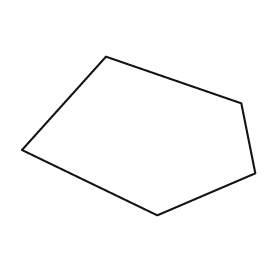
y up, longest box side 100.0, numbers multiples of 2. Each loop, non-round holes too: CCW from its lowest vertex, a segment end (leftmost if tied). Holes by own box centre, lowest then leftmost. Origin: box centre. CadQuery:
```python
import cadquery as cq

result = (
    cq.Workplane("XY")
    .moveTo(8.0, -34.0)
    .lineTo(50.0, -16.0)
    .lineTo(44.0, 14.0)
    .lineTo(-14.0, 34.0)
    .lineTo(-50.0, -6.0)
    .close()
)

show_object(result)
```